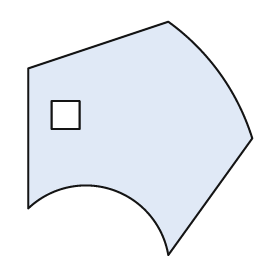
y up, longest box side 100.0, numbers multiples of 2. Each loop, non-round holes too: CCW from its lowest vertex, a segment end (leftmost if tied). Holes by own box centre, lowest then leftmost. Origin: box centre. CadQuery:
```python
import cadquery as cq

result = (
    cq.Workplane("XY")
    .moveTo(12.0, -50.0)
    .lineTo(48.0, 0.0)
    .threePointArc((34.0, 28.0), (12.0, 50.0))
    .lineTo(-48.0, 30.0)
    .lineTo(-48.0, -30.0)
    .threePointArc((-12.0, -22.0), (12.0, -50.0))
    .close()
    .moveTo(-38.0, 4.0)
    .lineTo(-26.0, 4.0)
    .lineTo(-26.0, 16.0)
    .lineTo(-38.0, 16.0)
    .close()
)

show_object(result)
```